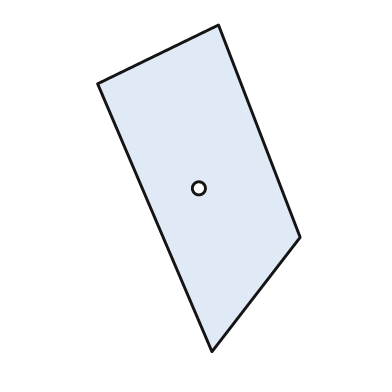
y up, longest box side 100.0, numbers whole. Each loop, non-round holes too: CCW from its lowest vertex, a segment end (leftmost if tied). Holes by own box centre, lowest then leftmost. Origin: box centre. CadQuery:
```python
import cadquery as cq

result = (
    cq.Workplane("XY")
    .moveTo(4.0, -50.0)
    .lineTo(31.0, -15.0)
    .lineTo(6.0, 50.0)
    .lineTo(-31.0, 32.0)
    .close()
    .moveTo(0.0, 0.0)
    .circle(2.0)
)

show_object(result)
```